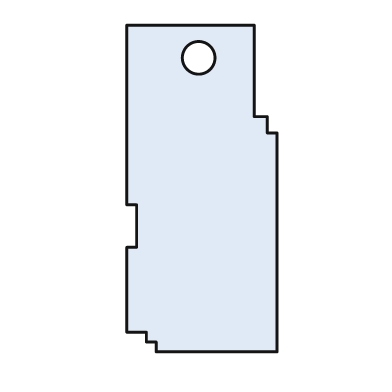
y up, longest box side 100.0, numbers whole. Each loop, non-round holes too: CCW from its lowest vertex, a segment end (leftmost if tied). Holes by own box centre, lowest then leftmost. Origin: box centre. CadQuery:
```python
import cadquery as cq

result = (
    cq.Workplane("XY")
    .moveTo(-14.0, -50.0)
    .lineTo(23.0, -50.0)
    .lineTo(23.0, 17.0)
    .lineTo(20.0, 17.0)
    .lineTo(20.0, 22.0)
    .lineTo(16.0, 22.0)
    .lineTo(16.0, 50.0)
    .lineTo(-23.0, 50.0)
    .lineTo(-23.0, -5.0)
    .lineTo(-20.0, -5.0)
    .lineTo(-20.0, -18.0)
    .lineTo(-23.0, -18.0)
    .lineTo(-23.0, -44.0)
    .lineTo(-17.0, -44.0)
    .lineTo(-17.0, -47.0)
    .lineTo(-14.0, -47.0)
    .close()
    .moveTo(-1.0, 40.0)
    .circle(5.0)
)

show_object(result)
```